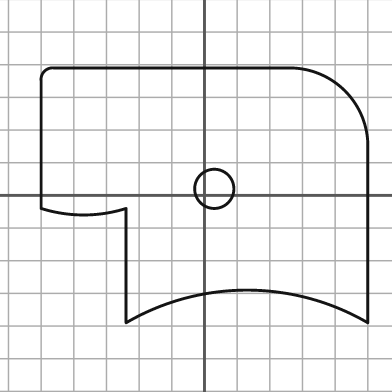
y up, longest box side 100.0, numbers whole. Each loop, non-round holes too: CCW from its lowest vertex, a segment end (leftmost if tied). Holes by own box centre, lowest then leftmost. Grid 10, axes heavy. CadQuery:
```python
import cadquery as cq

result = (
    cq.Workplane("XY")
    .moveTo(-24.0, -39.0)
    .threePointArc((13.0, -29.0), (50.0, -39.0))
    .lineTo(50.0, 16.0)
    .threePointArc((43.0, 32.0), (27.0, 39.0))
    .lineTo(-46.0, 39.0)
    .threePointArc((-49.0, 38.0), (-50.0, 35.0))
    .lineTo(-50.0, -4.0)
    .threePointArc((-37.0, -6.0), (-24.0, -4.0))
    .close()
    .moveTo(3.0, 2.0)
    .circle(6.0)
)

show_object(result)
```